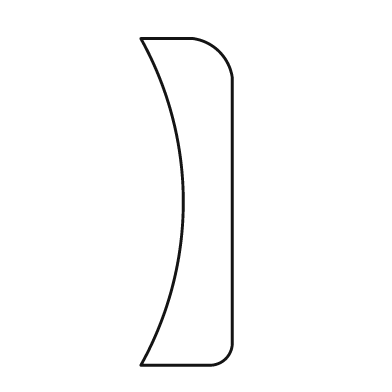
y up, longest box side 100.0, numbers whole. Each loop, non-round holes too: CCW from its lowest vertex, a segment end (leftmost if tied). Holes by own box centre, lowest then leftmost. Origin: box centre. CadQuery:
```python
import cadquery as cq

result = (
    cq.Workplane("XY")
    .moveTo(-14.0, -50.0)
    .lineTo(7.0, -50.0)
    .threePointArc((12.0, -48.0), (14.0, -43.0))
    .lineTo(14.0, 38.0)
    .threePointArc((10.0, 46.0), (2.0, 50.0))
    .lineTo(-14.0, 50.0)
    .threePointArc((-1.0, 0.0), (-14.0, -50.0))
    .close()
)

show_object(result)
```